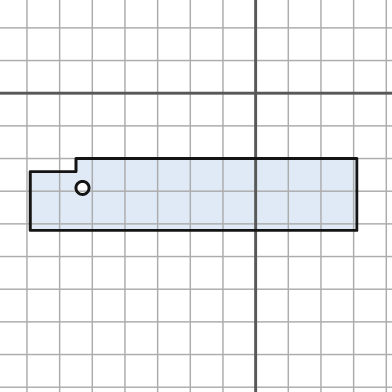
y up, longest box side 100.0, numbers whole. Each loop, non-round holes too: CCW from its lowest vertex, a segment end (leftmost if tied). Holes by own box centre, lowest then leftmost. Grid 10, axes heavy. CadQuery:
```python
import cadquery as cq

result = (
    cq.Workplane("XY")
    .moveTo(-69.0, -42.0)
    .lineTo(31.0, -42.0)
    .lineTo(31.0, -20.0)
    .lineTo(-55.0, -20.0)
    .lineTo(-55.0, -24.0)
    .lineTo(-69.0, -24.0)
    .close()
    .moveTo(-53.0, -29.0)
    .circle(2.0)
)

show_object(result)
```